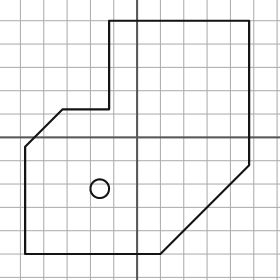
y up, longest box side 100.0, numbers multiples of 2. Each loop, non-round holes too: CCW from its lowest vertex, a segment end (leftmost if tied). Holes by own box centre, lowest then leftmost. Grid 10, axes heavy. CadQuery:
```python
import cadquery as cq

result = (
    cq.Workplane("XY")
    .moveTo(-48.0, -50.0)
    .lineTo(10.0, -50.0)
    .lineTo(48.0, -12.0)
    .lineTo(48.0, 50.0)
    .lineTo(-12.0, 50.0)
    .lineTo(-12.0, 12.0)
    .lineTo(-32.0, 12.0)
    .lineTo(-48.0, -4.0)
    .close()
    .moveTo(-16.0, -22.0)
    .circle(4.0)
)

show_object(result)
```